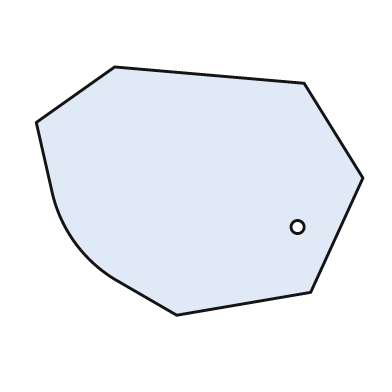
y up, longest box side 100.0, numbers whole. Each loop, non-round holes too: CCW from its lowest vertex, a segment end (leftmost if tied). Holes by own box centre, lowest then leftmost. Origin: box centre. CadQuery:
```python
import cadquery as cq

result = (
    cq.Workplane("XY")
    .moveTo(-7.0, -38.0)
    .lineTo(34.0, -31.0)
    .lineTo(50.0, 4.0)
    .lineTo(32.0, 33.0)
    .lineTo(-26.0, 38.0)
    .lineTo(-50.0, 21.0)
    .lineTo(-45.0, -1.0)
    .threePointArc((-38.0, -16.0), (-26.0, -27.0))
    .close()
    .moveTo(30.0, -11.0)
    .circle(2.0)
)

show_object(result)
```